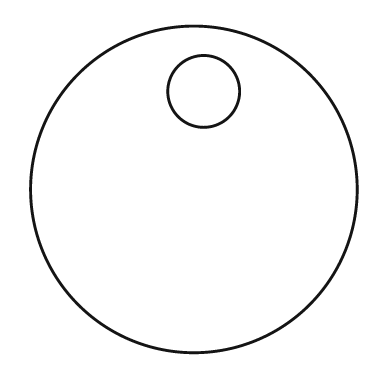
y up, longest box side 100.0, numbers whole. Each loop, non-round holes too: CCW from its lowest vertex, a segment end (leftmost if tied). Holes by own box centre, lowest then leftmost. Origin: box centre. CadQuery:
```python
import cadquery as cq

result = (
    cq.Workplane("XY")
    .moveTo(0.0, 0.0)
    .circle(50.0)
    .moveTo(3.0, 30.0)
    .circle(11.0)
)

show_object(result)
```